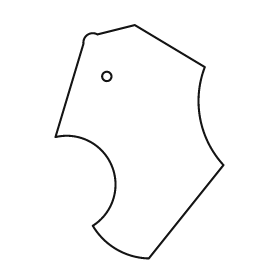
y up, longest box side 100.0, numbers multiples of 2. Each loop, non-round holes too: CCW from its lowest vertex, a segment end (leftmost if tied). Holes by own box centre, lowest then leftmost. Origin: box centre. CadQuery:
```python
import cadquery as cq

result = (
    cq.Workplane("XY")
    .moveTo(4.0, -50.0)
    .lineTo(36.0, -10.0)
    .threePointArc((26.0, 10.0), (28.0, 32.0))
    .lineTo(-2.0, 50.0)
    .lineTo(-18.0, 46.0)
    .threePointArc((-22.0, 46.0), (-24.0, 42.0))
    .lineTo(-36.0, 2.0)
    .threePointArc((-12.0, -10.0), (-20.0, -36.0))
    .threePointArc((-10.0, -46.0), (4.0, -50.0))
    .close()
    .moveTo(-14.0, 28.0)
    .circle(2.0)
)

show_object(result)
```